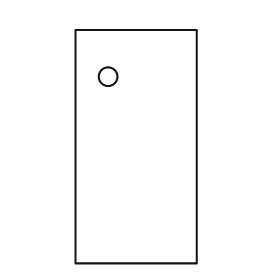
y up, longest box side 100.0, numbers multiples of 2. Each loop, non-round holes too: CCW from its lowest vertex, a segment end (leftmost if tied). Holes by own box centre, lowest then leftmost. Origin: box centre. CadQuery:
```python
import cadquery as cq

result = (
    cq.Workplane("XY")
    .moveTo(-26.0, -50.0)
    .lineTo(26.0, -50.0)
    .lineTo(26.0, 50.0)
    .lineTo(-26.0, 50.0)
    .close()
    .moveTo(-12.0, 30.0)
    .circle(4.0)
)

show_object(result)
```